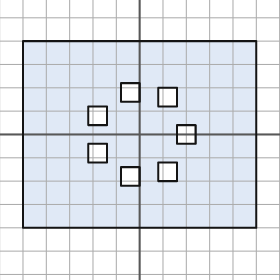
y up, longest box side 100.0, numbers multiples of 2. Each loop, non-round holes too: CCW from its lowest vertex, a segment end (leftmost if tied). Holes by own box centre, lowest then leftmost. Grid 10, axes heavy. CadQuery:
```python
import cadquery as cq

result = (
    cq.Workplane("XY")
    .moveTo(-50.0, -40.0)
    .lineTo(50.0, -40.0)
    .lineTo(50.0, 40.0)
    .lineTo(-50.0, 40.0)
    .close()
    .moveTo(-8.0, -22.0)
    .lineTo(0.0, -22.0)
    .lineTo(0.0, -14.0)
    .lineTo(-8.0, -14.0)
    .close()
    .moveTo(8.0, -20.0)
    .lineTo(16.0, -20.0)
    .lineTo(16.0, -12.0)
    .lineTo(8.0, -12.0)
    .close()
    .moveTo(-22.0, -12.0)
    .lineTo(-14.0, -12.0)
    .lineTo(-14.0, -4.0)
    .lineTo(-22.0, -4.0)
    .close()
    .moveTo(16.0, -4.0)
    .lineTo(24.0, -4.0)
    .lineTo(24.0, 4.0)
    .lineTo(16.0, 4.0)
    .close()
    .moveTo(-22.0, 4.0)
    .lineTo(-14.0, 4.0)
    .lineTo(-14.0, 12.0)
    .lineTo(-22.0, 12.0)
    .close()
    .moveTo(8.0, 12.0)
    .lineTo(16.0, 12.0)
    .lineTo(16.0, 20.0)
    .lineTo(8.0, 20.0)
    .close()
    .moveTo(-8.0, 14.0)
    .lineTo(0.0, 14.0)
    .lineTo(0.0, 22.0)
    .lineTo(-8.0, 22.0)
    .close()
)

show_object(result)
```